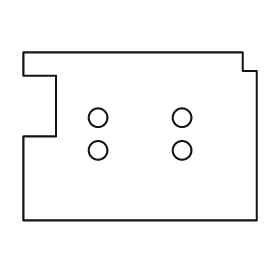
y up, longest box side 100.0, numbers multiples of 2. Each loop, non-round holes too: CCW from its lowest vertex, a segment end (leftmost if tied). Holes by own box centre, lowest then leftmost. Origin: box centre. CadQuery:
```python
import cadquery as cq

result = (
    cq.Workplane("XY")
    .moveTo(-50.0, -36.0)
    .lineTo(50.0, -36.0)
    .lineTo(50.0, 28.0)
    .lineTo(44.0, 28.0)
    .lineTo(44.0, 36.0)
    .lineTo(-50.0, 36.0)
    .lineTo(-50.0, 26.0)
    .lineTo(-36.0, 26.0)
    .lineTo(-36.0, 0.0)
    .lineTo(-50.0, 0.0)
    .close()
    .moveTo(-18.0, -6.0)
    .circle(4.0)
    .moveTo(18.0, -6.0)
    .circle(4.0)
    .moveTo(-18.0, 8.0)
    .circle(4.0)
    .moveTo(18.0, 8.0)
    .circle(4.0)
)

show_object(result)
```